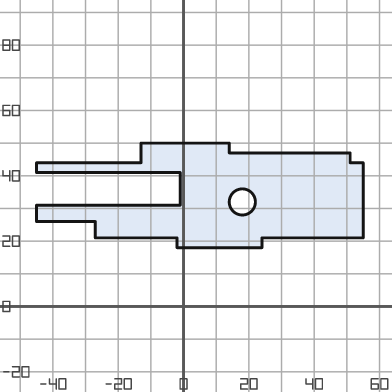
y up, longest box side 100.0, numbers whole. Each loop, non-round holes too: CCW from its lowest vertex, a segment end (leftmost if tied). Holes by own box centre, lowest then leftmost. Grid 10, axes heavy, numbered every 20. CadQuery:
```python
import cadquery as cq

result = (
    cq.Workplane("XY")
    .moveTo(-2.0, 18.0)
    .lineTo(24.0, 18.0)
    .lineTo(24.0, 21.0)
    .lineTo(55.0, 21.0)
    .lineTo(55.0, 44.0)
    .lineTo(51.0, 44.0)
    .lineTo(51.0, 47.0)
    .lineTo(14.0, 47.0)
    .lineTo(14.0, 50.0)
    .lineTo(-13.0, 50.0)
    .lineTo(-13.0, 44.0)
    .lineTo(-45.0, 44.0)
    .lineTo(-45.0, 41.0)
    .lineTo(-1.0, 41.0)
    .lineTo(-1.0, 31.0)
    .lineTo(-45.0, 31.0)
    .lineTo(-45.0, 26.0)
    .lineTo(-27.0, 26.0)
    .lineTo(-27.0, 21.0)
    .lineTo(-2.0, 21.0)
    .close()
    .moveTo(18.0, 32.0)
    .circle(4.0)
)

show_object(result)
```